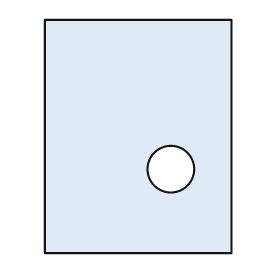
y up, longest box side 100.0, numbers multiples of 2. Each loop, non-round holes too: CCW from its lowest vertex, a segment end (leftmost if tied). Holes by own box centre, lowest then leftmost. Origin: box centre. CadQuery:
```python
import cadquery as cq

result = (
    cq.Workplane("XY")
    .moveTo(-40.0, -50.0)
    .lineTo(40.0, -50.0)
    .lineTo(40.0, 50.0)
    .lineTo(-40.0, 50.0)
    .close()
    .moveTo(14.0, -14.0)
    .circle(10.0)
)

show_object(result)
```